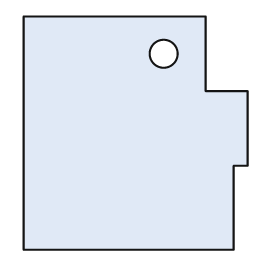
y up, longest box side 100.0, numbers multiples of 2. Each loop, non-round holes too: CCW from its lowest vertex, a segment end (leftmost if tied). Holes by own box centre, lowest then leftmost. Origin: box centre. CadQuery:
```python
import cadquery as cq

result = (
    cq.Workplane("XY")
    .moveTo(-48.0, -50.0)
    .lineTo(42.0, -50.0)
    .lineTo(42.0, -14.0)
    .lineTo(48.0, -14.0)
    .lineTo(48.0, 18.0)
    .lineTo(30.0, 18.0)
    .lineTo(30.0, 50.0)
    .lineTo(-48.0, 50.0)
    .close()
    .moveTo(12.0, 34.0)
    .circle(6.0)
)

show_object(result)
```